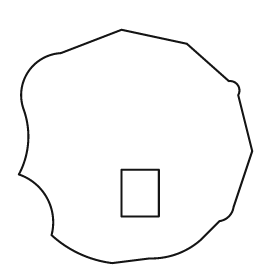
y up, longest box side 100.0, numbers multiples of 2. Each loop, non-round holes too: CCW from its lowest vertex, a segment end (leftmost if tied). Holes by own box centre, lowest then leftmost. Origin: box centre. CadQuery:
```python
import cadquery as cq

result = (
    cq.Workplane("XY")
    .moveTo(-10.0, -50.0)
    .lineTo(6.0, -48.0)
    .threePointArc((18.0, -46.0), (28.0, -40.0))
    .lineTo(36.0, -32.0)
    .threePointArc((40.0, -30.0), (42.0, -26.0))
    .lineTo(50.0, -2.0)
    .lineTo(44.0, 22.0)
    .threePointArc((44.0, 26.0), (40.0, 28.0))
    .lineTo(22.0, 44.0)
    .lineTo(-6.0, 50.0)
    .lineTo(-32.0, 40.0)
    .threePointArc((-46.0, 32.0), (-48.0, 16.0))
    .threePointArc((-46.0, 2.0), (-50.0, -12.0))
    .threePointArc((-38.0, -22.0), (-36.0, -38.0))
    .threePointArc((-24.0, -46.0), (-10.0, -50.0))
    .close()
    .moveTo(-6.0, -30.0)
    .lineTo(10.0, -30.0)
    .lineTo(10.0, -10.0)
    .lineTo(-6.0, -10.0)
    .close()
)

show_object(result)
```